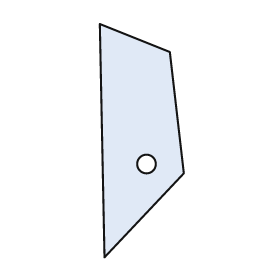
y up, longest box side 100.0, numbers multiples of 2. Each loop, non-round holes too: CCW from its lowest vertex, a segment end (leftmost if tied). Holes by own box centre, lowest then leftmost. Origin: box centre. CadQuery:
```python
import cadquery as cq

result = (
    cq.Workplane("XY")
    .moveTo(-16.0, -50.0)
    .lineTo(18.0, -14.0)
    .lineTo(12.0, 38.0)
    .lineTo(-18.0, 50.0)
    .close()
    .moveTo(2.0, -10.0)
    .circle(4.0)
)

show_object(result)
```